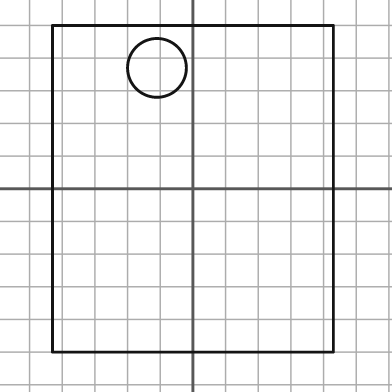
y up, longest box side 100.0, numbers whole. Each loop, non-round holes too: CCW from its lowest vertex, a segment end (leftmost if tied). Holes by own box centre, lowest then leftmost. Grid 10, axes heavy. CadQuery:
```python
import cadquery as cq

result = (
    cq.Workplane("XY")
    .moveTo(-43.0, -50.0)
    .lineTo(43.0, -50.0)
    .lineTo(43.0, 50.0)
    .lineTo(-43.0, 50.0)
    .close()
    .moveTo(-11.0, 37.0)
    .circle(9.0)
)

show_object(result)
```